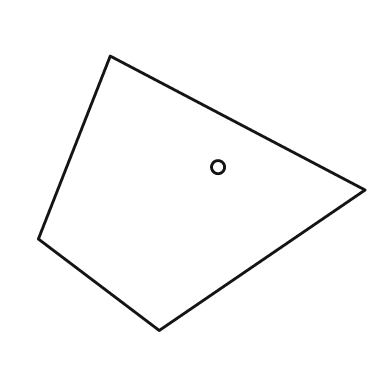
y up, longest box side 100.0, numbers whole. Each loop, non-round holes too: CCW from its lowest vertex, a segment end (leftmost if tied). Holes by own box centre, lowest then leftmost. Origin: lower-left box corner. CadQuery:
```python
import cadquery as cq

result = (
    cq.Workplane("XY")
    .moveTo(37.0, 0.0)
    .lineTo(100.0, 43.0)
    .lineTo(22.0, 84.0)
    .lineTo(0.0, 28.0)
    .close()
    .moveTo(55.0, 50.0)
    .circle(2.0)
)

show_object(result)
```